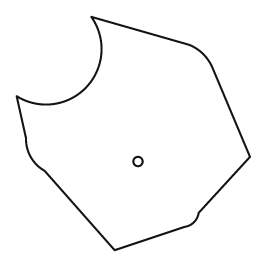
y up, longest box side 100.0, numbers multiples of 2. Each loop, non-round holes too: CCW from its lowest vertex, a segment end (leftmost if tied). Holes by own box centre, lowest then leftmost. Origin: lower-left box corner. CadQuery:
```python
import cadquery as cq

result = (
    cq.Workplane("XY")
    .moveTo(42.0, 0.0)
    .lineTo(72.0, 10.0)
    .threePointArc((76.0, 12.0), (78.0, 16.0))
    .lineTo(100.0, 40.0)
    .lineTo(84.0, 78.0)
    .threePointArc((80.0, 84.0), (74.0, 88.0))
    .lineTo(32.0, 100.0)
    .threePointArc((30.0, 70.0), (0.0, 66.0))
    .lineTo(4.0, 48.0)
    .threePointArc((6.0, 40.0), (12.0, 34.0))
    .close()
    .moveTo(52.0, 38.0)
    .circle(2.0)
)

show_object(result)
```